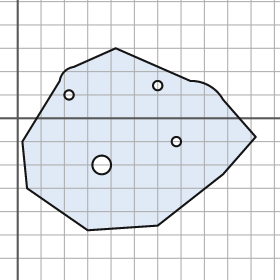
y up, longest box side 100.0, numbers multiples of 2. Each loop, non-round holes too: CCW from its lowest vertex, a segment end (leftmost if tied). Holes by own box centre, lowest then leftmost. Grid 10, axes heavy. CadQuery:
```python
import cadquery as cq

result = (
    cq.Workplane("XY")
    .moveTo(30.0, -48.0)
    .lineTo(60.0, -46.0)
    .lineTo(88.0, -24.0)
    .lineTo(102.0, -8.0)
    .lineTo(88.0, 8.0)
    .threePointArc((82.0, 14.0), (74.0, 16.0))
    .lineTo(42.0, 30.0)
    .lineTo(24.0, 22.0)
    .threePointArc((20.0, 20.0), (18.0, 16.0))
    .lineTo(2.0, -10.0)
    .lineTo(4.0, -30.0)
    .close()
    .moveTo(36.0, -20.0)
    .circle(4.0)
    .moveTo(68.0, -10.0)
    .circle(2.0)
    .moveTo(22.0, 10.0)
    .circle(2.0)
    .moveTo(60.0, 14.0)
    .circle(2.0)
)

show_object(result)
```